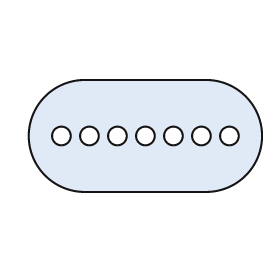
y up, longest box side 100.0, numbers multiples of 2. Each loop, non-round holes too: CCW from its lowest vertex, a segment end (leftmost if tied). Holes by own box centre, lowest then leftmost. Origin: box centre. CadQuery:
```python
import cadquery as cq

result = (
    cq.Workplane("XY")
    .moveTo(-26.0, -24.0)
    .lineTo(26.0, -24.0)
    .threePointArc((50.0, 0.0), (26.0, 24.0))
    .lineTo(-26.0, 24.0)
    .threePointArc((-50.0, 0.0), (-26.0, -24.0))
    .close()
    .moveTo(-36.0, 0.0)
    .circle(4.0)
    .moveTo(-24.0, 0.0)
    .circle(4.0)
    .moveTo(-12.0, 0.0)
    .circle(4.0)
    .moveTo(0.0, 0.0)
    .circle(4.0)
    .moveTo(12.0, 0.0)
    .circle(4.0)
    .moveTo(24.0, 0.0)
    .circle(4.0)
    .moveTo(36.0, 0.0)
    .circle(4.0)
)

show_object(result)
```